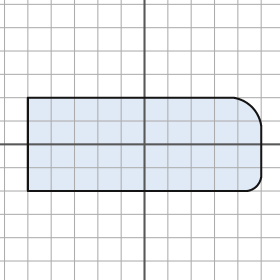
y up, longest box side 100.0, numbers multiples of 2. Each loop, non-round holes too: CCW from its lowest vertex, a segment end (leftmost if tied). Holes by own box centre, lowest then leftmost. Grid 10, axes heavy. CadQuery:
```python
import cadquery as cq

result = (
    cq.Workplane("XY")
    .moveTo(-50.0, -20.0)
    .lineTo(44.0, -20.0)
    .threePointArc((48.0, -18.0), (50.0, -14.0))
    .lineTo(50.0, 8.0)
    .threePointArc((46.0, 16.0), (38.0, 20.0))
    .lineTo(-50.0, 20.0)
    .close()
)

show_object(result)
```